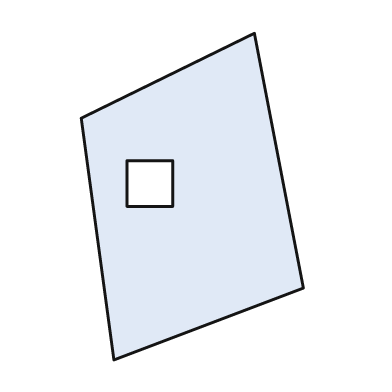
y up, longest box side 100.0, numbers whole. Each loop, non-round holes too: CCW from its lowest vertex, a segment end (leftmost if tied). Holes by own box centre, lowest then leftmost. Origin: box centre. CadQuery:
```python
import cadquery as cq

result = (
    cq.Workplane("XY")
    .moveTo(-24.0, -50.0)
    .lineTo(34.0, -28.0)
    .lineTo(19.0, 50.0)
    .lineTo(-34.0, 24.0)
    .close()
    .moveTo(-20.0, -3.0)
    .lineTo(-6.0, -3.0)
    .lineTo(-6.0, 11.0)
    .lineTo(-20.0, 11.0)
    .close()
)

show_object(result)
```